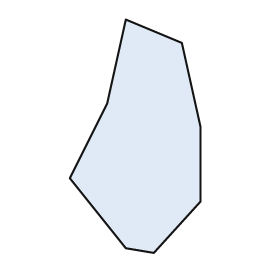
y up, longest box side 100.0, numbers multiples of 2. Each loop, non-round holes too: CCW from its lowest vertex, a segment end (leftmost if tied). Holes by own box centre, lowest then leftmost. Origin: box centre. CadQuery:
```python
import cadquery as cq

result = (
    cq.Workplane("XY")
    .moveTo(8.0, -50.0)
    .lineTo(28.0, -28.0)
    .lineTo(28.0, 4.0)
    .lineTo(20.0, 40.0)
    .lineTo(-4.0, 50.0)
    .lineTo(-12.0, 14.0)
    .lineTo(-28.0, -18.0)
    .lineTo(-4.0, -48.0)
    .close()
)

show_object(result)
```